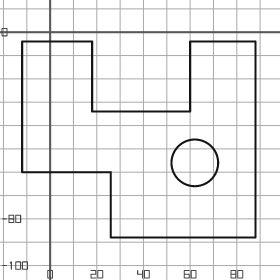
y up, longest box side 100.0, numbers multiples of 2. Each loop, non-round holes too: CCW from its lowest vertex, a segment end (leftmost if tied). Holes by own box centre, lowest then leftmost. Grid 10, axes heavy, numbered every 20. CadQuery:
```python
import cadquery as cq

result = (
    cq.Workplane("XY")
    .moveTo(26.0, -88.0)
    .lineTo(88.0, -88.0)
    .lineTo(88.0, -4.0)
    .lineTo(60.0, -4.0)
    .lineTo(60.0, -34.0)
    .lineTo(18.0, -34.0)
    .lineTo(18.0, -4.0)
    .lineTo(-12.0, -4.0)
    .lineTo(-12.0, -60.0)
    .lineTo(26.0, -60.0)
    .close()
    .moveTo(62.0, -56.0)
    .circle(10.0)
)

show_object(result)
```